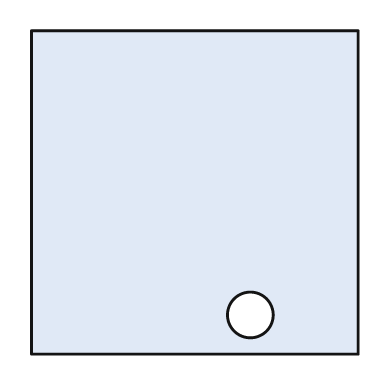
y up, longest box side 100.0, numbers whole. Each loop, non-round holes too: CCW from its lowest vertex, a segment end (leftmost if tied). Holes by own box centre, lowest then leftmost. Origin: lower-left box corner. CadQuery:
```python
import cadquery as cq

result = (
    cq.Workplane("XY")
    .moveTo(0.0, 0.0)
    .lineTo(100.0, 0.0)
    .lineTo(100.0, 99.0)
    .lineTo(0.0, 99.0)
    .close()
    .moveTo(67.0, 12.0)
    .circle(7.0)
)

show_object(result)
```